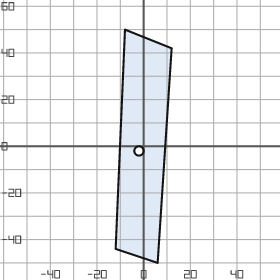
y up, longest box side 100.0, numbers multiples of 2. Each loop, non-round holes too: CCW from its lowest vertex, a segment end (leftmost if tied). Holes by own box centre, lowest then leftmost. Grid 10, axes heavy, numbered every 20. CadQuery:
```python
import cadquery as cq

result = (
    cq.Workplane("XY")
    .moveTo(6.0, -50.0)
    .lineTo(12.0, 42.0)
    .lineTo(-8.0, 50.0)
    .lineTo(-12.0, -44.0)
    .close()
    .moveTo(-2.0, -2.0)
    .circle(2.0)
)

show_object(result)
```